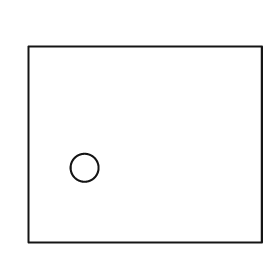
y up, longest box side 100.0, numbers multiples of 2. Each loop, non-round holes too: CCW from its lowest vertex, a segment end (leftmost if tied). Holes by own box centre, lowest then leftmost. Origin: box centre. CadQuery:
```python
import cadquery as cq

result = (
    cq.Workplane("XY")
    .moveTo(-50.0, -42.0)
    .lineTo(50.0, -42.0)
    .lineTo(50.0, 42.0)
    .lineTo(-50.0, 42.0)
    .close()
    .moveTo(-26.0, -10.0)
    .circle(6.0)
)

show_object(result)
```